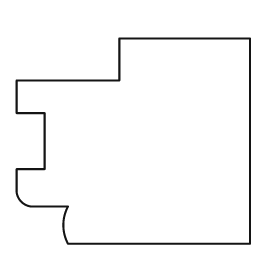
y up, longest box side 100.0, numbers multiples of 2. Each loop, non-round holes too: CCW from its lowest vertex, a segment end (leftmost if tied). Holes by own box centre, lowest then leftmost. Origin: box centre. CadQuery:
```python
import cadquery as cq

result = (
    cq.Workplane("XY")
    .moveTo(-28.0, -44.0)
    .lineTo(50.0, -44.0)
    .lineTo(50.0, 44.0)
    .lineTo(-6.0, 44.0)
    .lineTo(-6.0, 26.0)
    .lineTo(-50.0, 26.0)
    .lineTo(-50.0, 12.0)
    .lineTo(-38.0, 12.0)
    .lineTo(-38.0, -12.0)
    .lineTo(-50.0, -12.0)
    .lineTo(-50.0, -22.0)
    .threePointArc((-48.0, -26.0), (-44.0, -28.0))
    .lineTo(-28.0, -28.0)
    .threePointArc((-30.0, -36.0), (-28.0, -44.0))
    .close()
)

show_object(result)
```